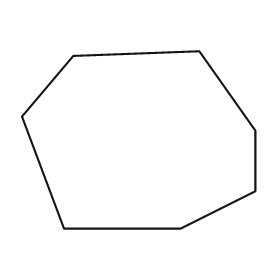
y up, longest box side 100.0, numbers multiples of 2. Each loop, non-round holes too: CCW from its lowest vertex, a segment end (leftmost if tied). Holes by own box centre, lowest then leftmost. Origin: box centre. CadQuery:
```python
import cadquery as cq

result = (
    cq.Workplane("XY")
    .moveTo(-32.0, -38.0)
    .lineTo(18.0, -38.0)
    .lineTo(50.0, -22.0)
    .lineTo(50.0, 4.0)
    .lineTo(26.0, 38.0)
    .lineTo(-28.0, 36.0)
    .lineTo(-50.0, 10.0)
    .close()
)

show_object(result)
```